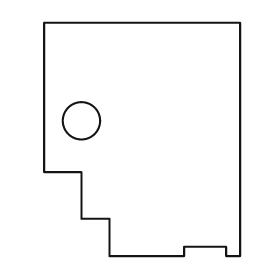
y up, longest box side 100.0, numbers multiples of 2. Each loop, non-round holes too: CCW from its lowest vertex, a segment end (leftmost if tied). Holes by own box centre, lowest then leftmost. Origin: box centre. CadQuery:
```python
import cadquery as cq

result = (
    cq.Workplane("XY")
    .moveTo(-14.0, -50.0)
    .lineTo(18.0, -50.0)
    .lineTo(18.0, -46.0)
    .lineTo(36.0, -46.0)
    .lineTo(36.0, -50.0)
    .lineTo(42.0, -50.0)
    .lineTo(42.0, 50.0)
    .lineTo(-42.0, 50.0)
    .lineTo(-42.0, -14.0)
    .lineTo(-26.0, -14.0)
    .lineTo(-26.0, -34.0)
    .lineTo(-14.0, -34.0)
    .close()
    .moveTo(-26.0, 8.0)
    .circle(8.0)
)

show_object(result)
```